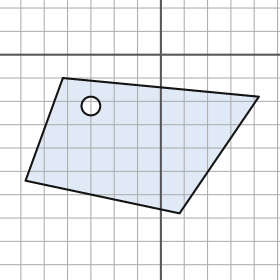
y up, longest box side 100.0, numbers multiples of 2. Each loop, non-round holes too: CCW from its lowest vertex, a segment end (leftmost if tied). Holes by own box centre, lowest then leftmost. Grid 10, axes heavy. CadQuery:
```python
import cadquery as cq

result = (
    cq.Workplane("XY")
    .moveTo(8.0, -68.0)
    .lineTo(42.0, -18.0)
    .lineTo(-42.0, -10.0)
    .lineTo(-58.0, -54.0)
    .close()
    .moveTo(-30.0, -22.0)
    .circle(4.0)
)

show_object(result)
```